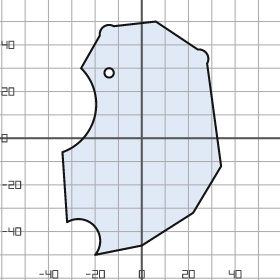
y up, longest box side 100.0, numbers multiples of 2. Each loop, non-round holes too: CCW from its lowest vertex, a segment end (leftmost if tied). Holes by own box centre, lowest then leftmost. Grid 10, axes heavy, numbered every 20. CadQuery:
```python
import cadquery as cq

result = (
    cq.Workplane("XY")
    .moveTo(-20.0, -50.0)
    .lineTo(0.0, -46.0)
    .lineTo(22.0, -32.0)
    .lineTo(34.0, -12.0)
    .lineTo(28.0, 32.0)
    .threePointArc((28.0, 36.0), (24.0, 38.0))
    .lineTo(6.0, 50.0)
    .lineTo(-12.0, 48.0)
    .threePointArc((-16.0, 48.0), (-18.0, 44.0))
    .lineTo(-26.0, 30.0)
    .threePointArc((-20.0, 10.0), (-34.0, -6.0))
    .lineTo(-32.0, -36.0)
    .threePointArc((-20.0, -38.0), (-20.0, -50.0))
    .close()
    .moveTo(-14.0, 28.0)
    .circle(2.0)
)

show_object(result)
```